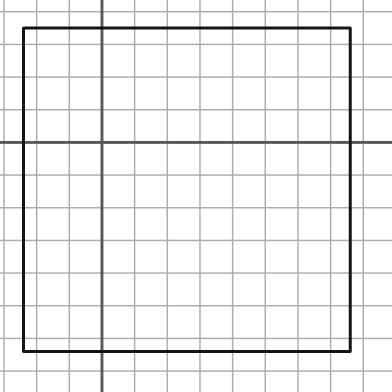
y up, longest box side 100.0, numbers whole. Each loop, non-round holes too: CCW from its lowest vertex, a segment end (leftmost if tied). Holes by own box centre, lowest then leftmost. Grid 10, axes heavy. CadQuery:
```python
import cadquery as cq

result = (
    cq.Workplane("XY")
    .moveTo(-24.0, -64.0)
    .lineTo(76.0, -64.0)
    .lineTo(76.0, 35.0)
    .lineTo(-24.0, 35.0)
    .close()
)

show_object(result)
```